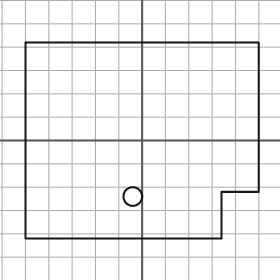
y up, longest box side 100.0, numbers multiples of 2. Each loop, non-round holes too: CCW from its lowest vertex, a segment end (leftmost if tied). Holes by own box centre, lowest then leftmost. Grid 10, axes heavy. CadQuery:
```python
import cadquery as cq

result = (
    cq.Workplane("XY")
    .moveTo(-50.0, -42.0)
    .lineTo(34.0, -42.0)
    .lineTo(34.0, -22.0)
    .lineTo(50.0, -22.0)
    .lineTo(50.0, 42.0)
    .lineTo(-50.0, 42.0)
    .close()
    .moveTo(-4.0, -24.0)
    .circle(4.0)
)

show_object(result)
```